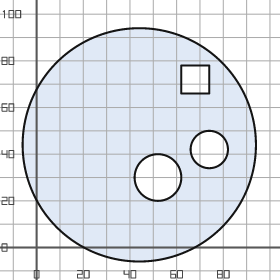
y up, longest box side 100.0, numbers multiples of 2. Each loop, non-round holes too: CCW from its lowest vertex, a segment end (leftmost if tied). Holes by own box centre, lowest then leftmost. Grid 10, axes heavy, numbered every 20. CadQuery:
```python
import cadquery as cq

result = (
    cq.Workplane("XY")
    .moveTo(44.0, 44.0)
    .circle(50.0)
    .moveTo(52.0, 30.0)
    .circle(10.0)
    .moveTo(74.0, 42.0)
    .circle(8.0)
    .moveTo(62.0, 66.0)
    .lineTo(74.0, 66.0)
    .lineTo(74.0, 78.0)
    .lineTo(62.0, 78.0)
    .close()
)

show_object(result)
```